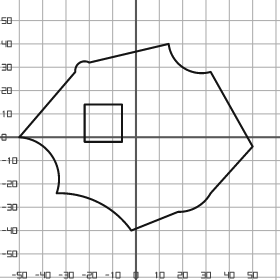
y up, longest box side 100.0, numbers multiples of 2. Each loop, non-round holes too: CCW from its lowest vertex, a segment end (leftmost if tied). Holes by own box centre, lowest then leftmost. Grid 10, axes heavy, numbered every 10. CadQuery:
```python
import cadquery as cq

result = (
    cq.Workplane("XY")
    .moveTo(-2.0, -40.0)
    .lineTo(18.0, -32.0)
    .threePointArc((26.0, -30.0), (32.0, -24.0))
    .lineTo(50.0, -4.0)
    .lineTo(32.0, 28.0)
    .threePointArc((20.0, 30.0), (14.0, 40.0))
    .lineTo(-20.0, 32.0)
    .threePointArc((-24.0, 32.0), (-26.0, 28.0))
    .lineTo(-50.0, 0.0)
    .threePointArc((-36.0, -8.0), (-34.0, -24.0))
    .threePointArc((-16.0, -28.0), (-2.0, -40.0))
    .close()
    .moveTo(-22.0, -2.0)
    .lineTo(-6.0, -2.0)
    .lineTo(-6.0, 14.0)
    .lineTo(-22.0, 14.0)
    .close()
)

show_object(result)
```